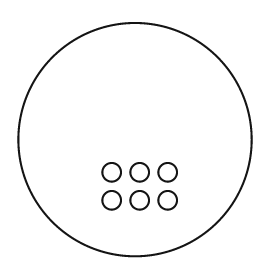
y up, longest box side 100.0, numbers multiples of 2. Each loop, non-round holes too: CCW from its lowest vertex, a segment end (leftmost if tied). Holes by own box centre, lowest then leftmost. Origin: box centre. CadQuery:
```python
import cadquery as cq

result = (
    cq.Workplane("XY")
    .moveTo(0.0, 0.0)
    .circle(50.0)
    .moveTo(-10.0, -26.0)
    .circle(4.0)
    .moveTo(2.0, -26.0)
    .circle(4.0)
    .moveTo(14.0, -26.0)
    .circle(4.0)
    .moveTo(-10.0, -14.0)
    .circle(4.0)
    .moveTo(2.0, -14.0)
    .circle(4.0)
    .moveTo(14.0, -14.0)
    .circle(4.0)
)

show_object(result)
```